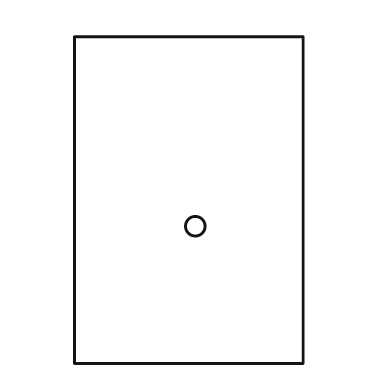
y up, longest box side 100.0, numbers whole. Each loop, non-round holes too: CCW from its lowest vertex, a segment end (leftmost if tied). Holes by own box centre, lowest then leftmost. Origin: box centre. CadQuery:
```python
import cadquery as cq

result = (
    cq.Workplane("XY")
    .moveTo(-35.0, -50.0)
    .lineTo(35.0, -50.0)
    .lineTo(35.0, 50.0)
    .lineTo(-35.0, 50.0)
    .close()
    .moveTo(2.0, -8.0)
    .circle(3.0)
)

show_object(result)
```